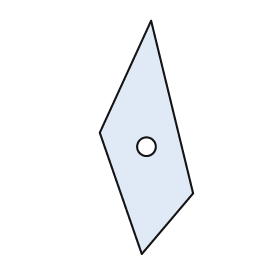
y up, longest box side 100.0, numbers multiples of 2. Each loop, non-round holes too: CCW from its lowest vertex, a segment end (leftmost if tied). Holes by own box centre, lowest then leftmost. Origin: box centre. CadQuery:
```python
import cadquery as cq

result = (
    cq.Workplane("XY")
    .moveTo(-2.0, -50.0)
    .lineTo(20.0, -24.0)
    .lineTo(2.0, 50.0)
    .lineTo(-20.0, 2.0)
    .close()
    .moveTo(0.0, -4.0)
    .circle(4.0)
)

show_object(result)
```